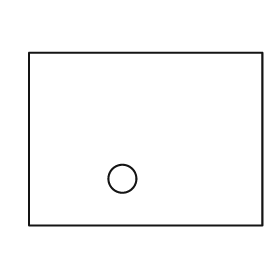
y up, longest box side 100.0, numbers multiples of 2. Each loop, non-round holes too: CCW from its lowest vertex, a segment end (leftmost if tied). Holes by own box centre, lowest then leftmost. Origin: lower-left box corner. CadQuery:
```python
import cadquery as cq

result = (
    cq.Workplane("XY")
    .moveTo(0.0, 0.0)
    .lineTo(100.0, 0.0)
    .lineTo(100.0, 74.0)
    .lineTo(0.0, 74.0)
    .close()
    .moveTo(40.0, 20.0)
    .circle(6.0)
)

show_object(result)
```